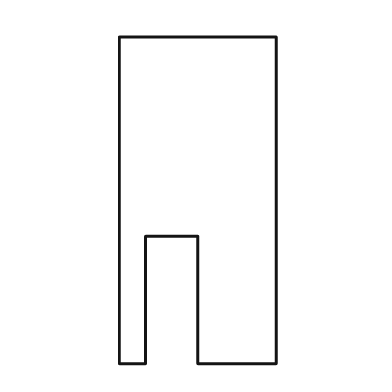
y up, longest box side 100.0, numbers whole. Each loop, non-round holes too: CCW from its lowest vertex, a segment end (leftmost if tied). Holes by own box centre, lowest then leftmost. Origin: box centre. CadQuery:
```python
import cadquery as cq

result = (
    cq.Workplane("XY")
    .moveTo(-24.0, -50.0)
    .lineTo(-16.0, -50.0)
    .lineTo(-16.0, -11.0)
    .lineTo(0.0, -11.0)
    .lineTo(0.0, -50.0)
    .lineTo(24.0, -50.0)
    .lineTo(24.0, 50.0)
    .lineTo(-24.0, 50.0)
    .close()
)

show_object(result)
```